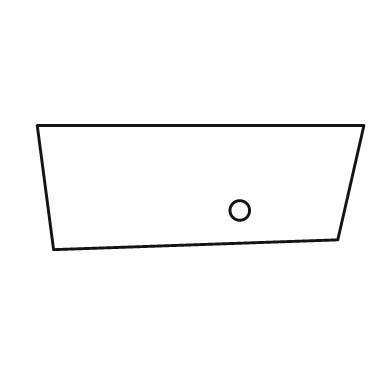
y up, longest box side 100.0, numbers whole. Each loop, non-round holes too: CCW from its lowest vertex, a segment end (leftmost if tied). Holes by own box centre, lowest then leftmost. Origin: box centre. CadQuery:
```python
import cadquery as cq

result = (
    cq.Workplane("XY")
    .moveTo(-45.0, -19.0)
    .lineTo(42.0, -16.0)
    .lineTo(50.0, 19.0)
    .lineTo(-50.0, 19.0)
    .close()
    .moveTo(12.0, -7.0)
    .circle(3.0)
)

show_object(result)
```